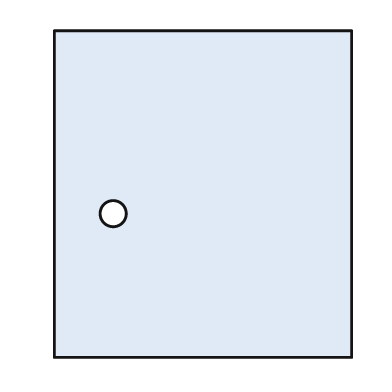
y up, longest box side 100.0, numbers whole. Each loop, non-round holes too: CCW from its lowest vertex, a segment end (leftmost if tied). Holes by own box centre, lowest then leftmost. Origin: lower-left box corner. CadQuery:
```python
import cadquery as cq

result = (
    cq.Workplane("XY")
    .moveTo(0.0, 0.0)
    .lineTo(91.0, 0.0)
    .lineTo(91.0, 100.0)
    .lineTo(0.0, 100.0)
    .close()
    .moveTo(18.0, 44.0)
    .circle(4.0)
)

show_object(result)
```